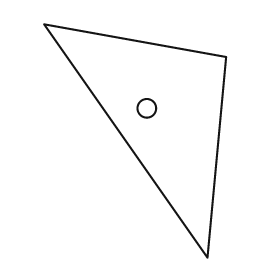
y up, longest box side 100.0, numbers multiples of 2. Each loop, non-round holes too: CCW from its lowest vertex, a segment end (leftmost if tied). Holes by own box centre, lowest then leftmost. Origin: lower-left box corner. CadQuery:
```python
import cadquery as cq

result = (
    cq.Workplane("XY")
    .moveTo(70.0, 0.0)
    .lineTo(78.0, 86.0)
    .lineTo(0.0, 100.0)
    .close()
    .moveTo(44.0, 64.0)
    .circle(4.0)
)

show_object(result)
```